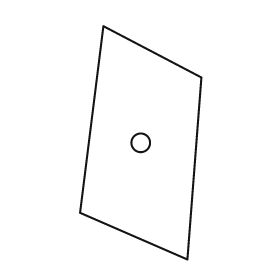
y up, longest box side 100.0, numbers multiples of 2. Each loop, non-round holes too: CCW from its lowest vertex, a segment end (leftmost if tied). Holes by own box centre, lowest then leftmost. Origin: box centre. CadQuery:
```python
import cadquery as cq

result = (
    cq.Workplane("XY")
    .moveTo(20.0, -50.0)
    .lineTo(26.0, 28.0)
    .lineTo(-16.0, 50.0)
    .lineTo(-26.0, -30.0)
    .close()
    .moveTo(0.0, 0.0)
    .circle(4.0)
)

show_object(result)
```